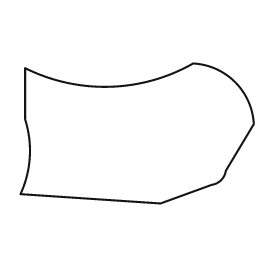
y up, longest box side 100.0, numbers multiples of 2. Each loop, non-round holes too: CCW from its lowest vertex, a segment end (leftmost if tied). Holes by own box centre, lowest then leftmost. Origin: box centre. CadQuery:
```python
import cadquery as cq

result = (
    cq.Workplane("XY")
    .moveTo(10.0, -30.0)
    .lineTo(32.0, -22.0)
    .threePointArc((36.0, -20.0), (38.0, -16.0))
    .lineTo(50.0, 4.0)
    .threePointArc((42.0, 22.0), (24.0, 30.0))
    .threePointArc((-12.0, 20.0), (-48.0, 28.0))
    .lineTo(-48.0, 6.0)
    .threePointArc((-46.0, -10.0), (-50.0, -26.0))
    .close()
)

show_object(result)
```